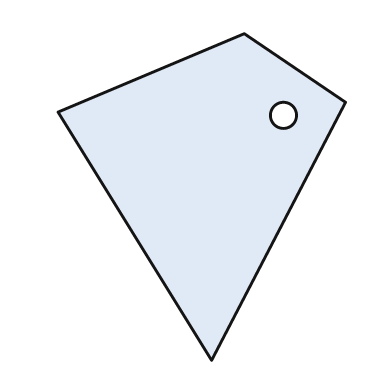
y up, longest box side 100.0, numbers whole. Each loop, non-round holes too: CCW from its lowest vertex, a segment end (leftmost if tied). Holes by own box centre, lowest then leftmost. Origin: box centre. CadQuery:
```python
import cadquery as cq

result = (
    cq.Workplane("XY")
    .moveTo(3.0, -50.0)
    .lineTo(44.0, 29.0)
    .lineTo(13.0, 50.0)
    .lineTo(-44.0, 26.0)
    .close()
    .moveTo(25.0, 25.0)
    .circle(4.0)
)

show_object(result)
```